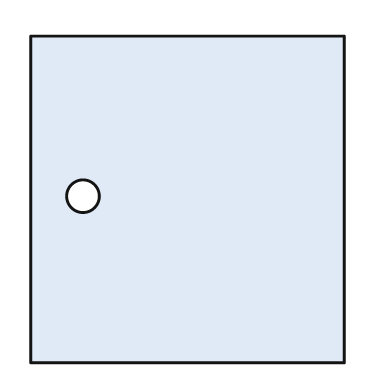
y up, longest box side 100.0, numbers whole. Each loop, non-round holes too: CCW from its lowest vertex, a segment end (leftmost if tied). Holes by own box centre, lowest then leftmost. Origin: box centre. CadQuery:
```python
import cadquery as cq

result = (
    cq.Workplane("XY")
    .moveTo(-48.0, -50.0)
    .lineTo(48.0, -50.0)
    .lineTo(48.0, 50.0)
    .lineTo(-48.0, 50.0)
    .close()
    .moveTo(-32.0, 1.0)
    .circle(5.0)
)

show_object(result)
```